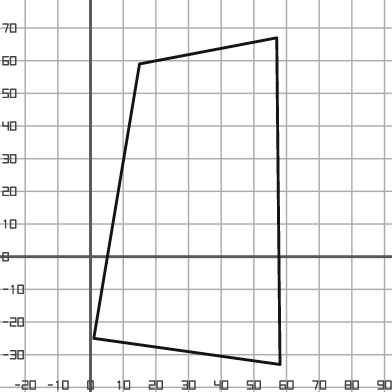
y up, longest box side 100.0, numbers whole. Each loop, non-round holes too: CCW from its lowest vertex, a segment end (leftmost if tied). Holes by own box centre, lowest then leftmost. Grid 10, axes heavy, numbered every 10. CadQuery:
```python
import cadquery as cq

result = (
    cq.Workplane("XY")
    .moveTo(58.0, -33.0)
    .lineTo(57.0, 67.0)
    .lineTo(15.0, 59.0)
    .lineTo(1.0, -25.0)
    .close()
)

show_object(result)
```